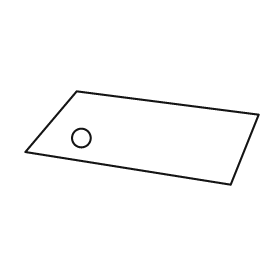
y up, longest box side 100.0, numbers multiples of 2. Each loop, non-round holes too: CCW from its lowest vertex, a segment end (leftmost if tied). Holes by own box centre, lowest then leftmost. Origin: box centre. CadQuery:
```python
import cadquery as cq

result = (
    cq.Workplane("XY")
    .moveTo(38.0, -20.0)
    .lineTo(50.0, 10.0)
    .lineTo(-28.0, 20.0)
    .lineTo(-50.0, -6.0)
    .close()
    .moveTo(-26.0, 0.0)
    .circle(4.0)
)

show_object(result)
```